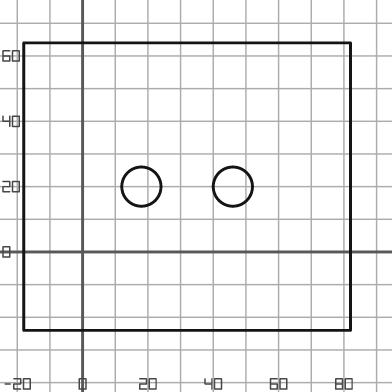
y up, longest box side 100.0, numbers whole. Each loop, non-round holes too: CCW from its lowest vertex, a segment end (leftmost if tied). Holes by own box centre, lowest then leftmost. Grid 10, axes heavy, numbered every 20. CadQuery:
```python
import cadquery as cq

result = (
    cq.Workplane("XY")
    .moveTo(-18.0, -24.0)
    .lineTo(82.0, -24.0)
    .lineTo(82.0, 64.0)
    .lineTo(-18.0, 64.0)
    .close()
    .moveTo(18.0, 20.0)
    .circle(6.0)
    .moveTo(46.0, 20.0)
    .circle(6.0)
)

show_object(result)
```